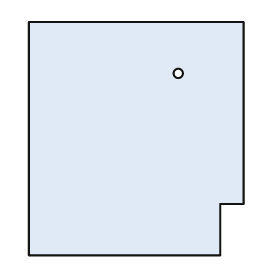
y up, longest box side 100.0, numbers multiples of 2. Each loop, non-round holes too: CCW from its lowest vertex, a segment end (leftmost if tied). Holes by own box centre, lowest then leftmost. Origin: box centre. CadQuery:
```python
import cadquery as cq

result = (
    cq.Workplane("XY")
    .moveTo(-46.0, -50.0)
    .lineTo(36.0, -50.0)
    .lineTo(36.0, -28.0)
    .lineTo(46.0, -28.0)
    .lineTo(46.0, 50.0)
    .lineTo(-46.0, 50.0)
    .close()
    .moveTo(18.0, 28.0)
    .circle(2.0)
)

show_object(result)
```